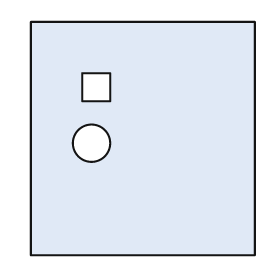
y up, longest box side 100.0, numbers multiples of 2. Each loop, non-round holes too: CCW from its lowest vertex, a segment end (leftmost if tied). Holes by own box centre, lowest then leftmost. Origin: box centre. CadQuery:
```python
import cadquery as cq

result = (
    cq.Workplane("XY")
    .moveTo(-48.0, -50.0)
    .lineTo(48.0, -50.0)
    .lineTo(48.0, 50.0)
    .lineTo(-48.0, 50.0)
    .close()
    .moveTo(-22.0, -2.0)
    .circle(8.0)
    .moveTo(-26.0, 16.0)
    .lineTo(-14.0, 16.0)
    .lineTo(-14.0, 28.0)
    .lineTo(-26.0, 28.0)
    .close()
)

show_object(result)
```